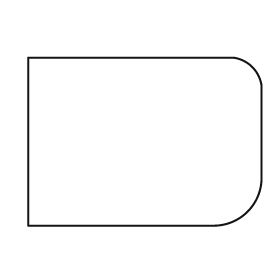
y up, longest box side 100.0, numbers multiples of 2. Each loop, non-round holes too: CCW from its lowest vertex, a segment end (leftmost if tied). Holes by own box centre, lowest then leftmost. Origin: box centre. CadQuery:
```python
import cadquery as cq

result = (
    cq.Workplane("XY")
    .moveTo(-50.0, -36.0)
    .lineTo(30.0, -36.0)
    .threePointArc((44.0, -30.0), (50.0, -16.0))
    .lineTo(50.0, 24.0)
    .threePointArc((46.0, 32.0), (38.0, 36.0))
    .lineTo(-50.0, 36.0)
    .close()
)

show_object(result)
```